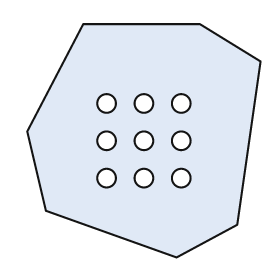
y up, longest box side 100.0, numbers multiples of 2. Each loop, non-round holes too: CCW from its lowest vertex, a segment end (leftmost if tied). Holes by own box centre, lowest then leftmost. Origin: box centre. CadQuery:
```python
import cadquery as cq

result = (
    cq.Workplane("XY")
    .moveTo(14.0, -50.0)
    .lineTo(40.0, -36.0)
    .lineTo(50.0, 34.0)
    .lineTo(24.0, 50.0)
    .lineTo(-26.0, 50.0)
    .lineTo(-50.0, 4.0)
    .lineTo(-42.0, -30.0)
    .close()
    .moveTo(-16.0, -16.0)
    .circle(4.0)
    .moveTo(0.0, -16.0)
    .circle(4.0)
    .moveTo(16.0, -16.0)
    .circle(4.0)
    .moveTo(-16.0, 0.0)
    .circle(4.0)
    .moveTo(0.0, 0.0)
    .circle(4.0)
    .moveTo(16.0, 0.0)
    .circle(4.0)
    .moveTo(-16.0, 16.0)
    .circle(4.0)
    .moveTo(0.0, 16.0)
    .circle(4.0)
    .moveTo(16.0, 16.0)
    .circle(4.0)
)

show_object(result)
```